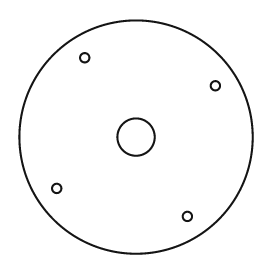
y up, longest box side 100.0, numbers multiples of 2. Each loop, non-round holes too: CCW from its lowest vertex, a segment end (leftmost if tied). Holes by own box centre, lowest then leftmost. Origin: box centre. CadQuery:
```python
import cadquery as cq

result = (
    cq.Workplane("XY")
    .moveTo(0.0, 0.0)
    .circle(50.0)
    .moveTo(22.0, -34.0)
    .circle(2.0)
    .moveTo(-34.0, -22.0)
    .circle(2.0)
    .moveTo(0.0, 0.0)
    .circle(8.0)
    .moveTo(34.0, 22.0)
    .circle(2.0)
    .moveTo(-22.0, 34.0)
    .circle(2.0)
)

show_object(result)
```